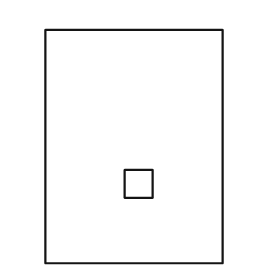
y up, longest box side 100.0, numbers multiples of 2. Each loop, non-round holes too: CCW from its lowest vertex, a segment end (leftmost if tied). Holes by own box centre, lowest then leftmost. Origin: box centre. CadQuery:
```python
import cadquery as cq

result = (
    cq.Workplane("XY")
    .moveTo(-38.0, -50.0)
    .lineTo(38.0, -50.0)
    .lineTo(38.0, 50.0)
    .lineTo(-38.0, 50.0)
    .close()
    .moveTo(-4.0, -22.0)
    .lineTo(8.0, -22.0)
    .lineTo(8.0, -10.0)
    .lineTo(-4.0, -10.0)
    .close()
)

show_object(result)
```